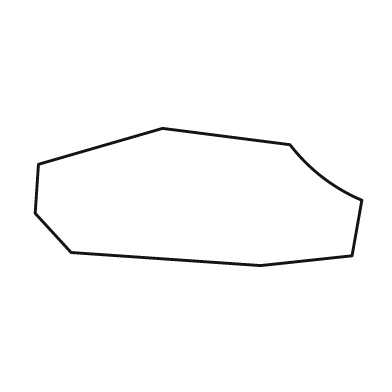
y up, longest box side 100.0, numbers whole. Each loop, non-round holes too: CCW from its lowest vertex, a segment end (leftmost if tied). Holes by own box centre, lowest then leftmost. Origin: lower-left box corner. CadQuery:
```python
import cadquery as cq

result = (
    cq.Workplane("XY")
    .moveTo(69.0, 0.0)
    .lineTo(97.0, 3.0)
    .lineTo(100.0, 20.0)
    .threePointArc((88.0, 27.0), (78.0, 37.0))
    .lineTo(39.0, 42.0)
    .lineTo(1.0, 31.0)
    .lineTo(0.0, 16.0)
    .lineTo(11.0, 4.0)
    .close()
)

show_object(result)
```